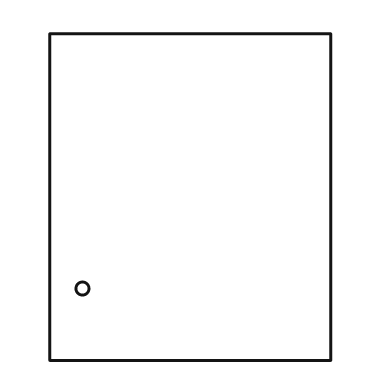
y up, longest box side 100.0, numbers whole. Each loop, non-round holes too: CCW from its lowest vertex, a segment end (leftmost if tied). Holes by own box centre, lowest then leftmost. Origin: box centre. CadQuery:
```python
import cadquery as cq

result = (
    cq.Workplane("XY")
    .moveTo(-43.0, -50.0)
    .lineTo(43.0, -50.0)
    .lineTo(43.0, 50.0)
    .lineTo(-43.0, 50.0)
    .close()
    .moveTo(-33.0, -28.0)
    .circle(2.0)
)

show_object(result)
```